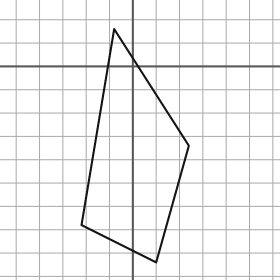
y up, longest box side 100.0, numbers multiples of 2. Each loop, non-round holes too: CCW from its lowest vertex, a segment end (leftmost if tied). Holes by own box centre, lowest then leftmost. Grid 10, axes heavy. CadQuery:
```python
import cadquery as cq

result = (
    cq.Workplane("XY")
    .moveTo(10.0, -84.0)
    .lineTo(24.0, -34.0)
    .lineTo(-8.0, 16.0)
    .lineTo(-22.0, -68.0)
    .close()
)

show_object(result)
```